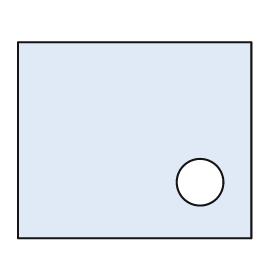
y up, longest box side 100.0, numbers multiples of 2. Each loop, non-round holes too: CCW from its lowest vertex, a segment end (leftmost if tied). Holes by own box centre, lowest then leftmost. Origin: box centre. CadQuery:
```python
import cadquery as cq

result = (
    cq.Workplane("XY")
    .moveTo(-50.0, -42.0)
    .lineTo(50.0, -42.0)
    .lineTo(50.0, 42.0)
    .lineTo(-50.0, 42.0)
    .close()
    .moveTo(28.0, -18.0)
    .circle(10.0)
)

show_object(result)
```